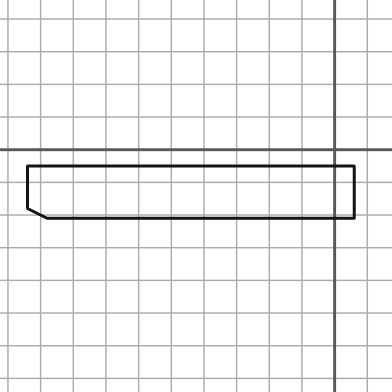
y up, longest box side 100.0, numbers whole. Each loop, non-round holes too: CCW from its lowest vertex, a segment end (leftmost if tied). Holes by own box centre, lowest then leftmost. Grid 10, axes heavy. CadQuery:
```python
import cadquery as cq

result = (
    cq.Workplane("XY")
    .moveTo(-88.0, -21.0)
    .lineTo(6.0, -21.0)
    .lineTo(6.0, -5.0)
    .lineTo(-94.0, -5.0)
    .lineTo(-94.0, -18.0)
    .close()
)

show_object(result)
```